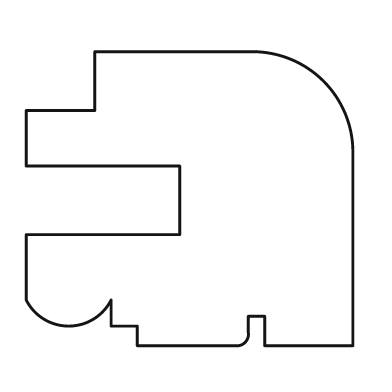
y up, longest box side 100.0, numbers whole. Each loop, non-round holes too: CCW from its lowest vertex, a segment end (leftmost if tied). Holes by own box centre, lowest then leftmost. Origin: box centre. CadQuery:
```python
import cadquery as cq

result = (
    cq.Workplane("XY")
    .moveTo(-16.0, -45.0)
    .lineTo(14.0, -45.0)
    .threePointArc((17.0, -44.0), (18.0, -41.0))
    .lineTo(18.0, -36.0)
    .lineTo(23.0, -36.0)
    .lineTo(23.0, -45.0)
    .lineTo(50.0, -45.0)
    .lineTo(50.0, 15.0)
    .threePointArc((41.0, 36.0), (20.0, 45.0))
    .lineTo(-29.0, 45.0)
    .lineTo(-29.0, 27.0)
    .lineTo(-50.0, 27.0)
    .lineTo(-50.0, 10.0)
    .lineTo(-3.0, 10.0)
    .lineTo(-3.0, -11.0)
    .lineTo(-50.0, -11.0)
    .lineTo(-50.0, -31.0)
    .threePointArc((-37.0, -39.0), (-24.0, -31.0))
    .lineTo(-24.0, -39.0)
    .lineTo(-16.0, -39.0)
    .close()
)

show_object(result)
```